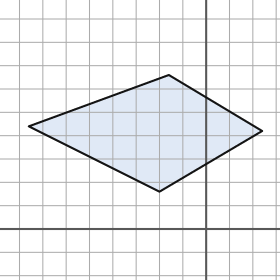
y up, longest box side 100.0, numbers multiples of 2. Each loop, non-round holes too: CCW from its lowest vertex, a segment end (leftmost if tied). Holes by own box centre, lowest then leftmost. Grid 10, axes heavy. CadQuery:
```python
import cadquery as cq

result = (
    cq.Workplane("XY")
    .moveTo(-20.0, 16.0)
    .lineTo(24.0, 42.0)
    .lineTo(-16.0, 66.0)
    .lineTo(-76.0, 44.0)
    .close()
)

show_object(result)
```